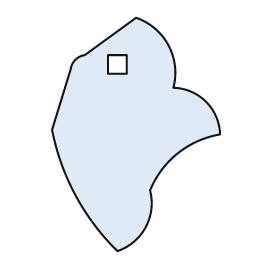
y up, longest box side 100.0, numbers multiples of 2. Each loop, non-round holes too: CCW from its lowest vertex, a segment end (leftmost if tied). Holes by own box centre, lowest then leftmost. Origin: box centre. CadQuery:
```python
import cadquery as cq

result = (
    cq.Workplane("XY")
    .moveTo(-8.0, -50.0)
    .threePointArc((4.0, -40.0), (6.0, -24.0))
    .threePointArc((18.0, -8.0), (36.0, 0.0))
    .threePointArc((30.0, 14.0), (16.0, 20.0))
    .threePointArc((14.0, 38.0), (0.0, 50.0))
    .lineTo(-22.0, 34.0)
    .threePointArc((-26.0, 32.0), (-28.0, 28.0))
    .lineTo(-36.0, 2.0)
    .threePointArc((-26.0, -26.0), (-8.0, -50.0))
    .close()
    .moveTo(-12.0, 26.0)
    .lineTo(-4.0, 26.0)
    .lineTo(-4.0, 34.0)
    .lineTo(-12.0, 34.0)
    .close()
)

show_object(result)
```